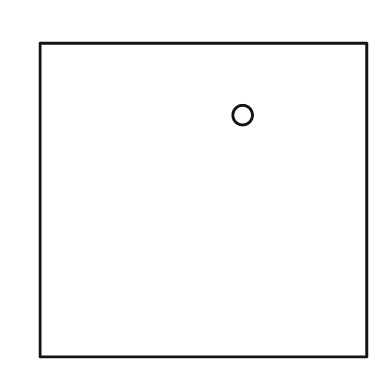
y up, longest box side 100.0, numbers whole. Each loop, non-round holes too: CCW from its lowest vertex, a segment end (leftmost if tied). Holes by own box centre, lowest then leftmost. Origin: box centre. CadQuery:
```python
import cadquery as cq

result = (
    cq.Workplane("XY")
    .moveTo(-50.0, -48.0)
    .lineTo(50.0, -48.0)
    .lineTo(50.0, 48.0)
    .lineTo(-50.0, 48.0)
    .close()
    .moveTo(12.0, 26.0)
    .circle(3.0)
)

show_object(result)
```